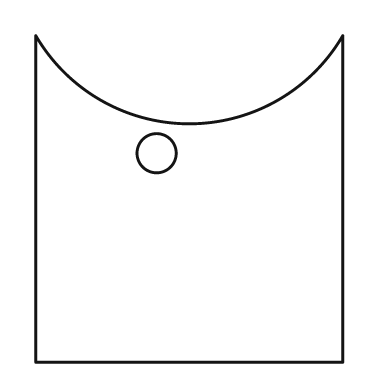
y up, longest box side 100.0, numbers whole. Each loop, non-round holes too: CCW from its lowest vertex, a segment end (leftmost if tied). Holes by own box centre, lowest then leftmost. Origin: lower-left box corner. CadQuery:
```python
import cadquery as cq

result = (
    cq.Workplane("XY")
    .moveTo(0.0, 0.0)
    .lineTo(94.0, 0.0)
    .lineTo(94.0, 100.0)
    .threePointArc((47.0, 73.0), (0.0, 100.0))
    .close()
    .moveTo(37.0, 64.0)
    .circle(6.0)
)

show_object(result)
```